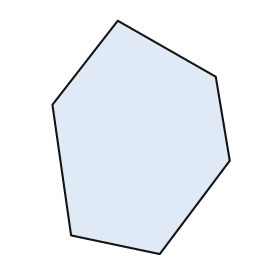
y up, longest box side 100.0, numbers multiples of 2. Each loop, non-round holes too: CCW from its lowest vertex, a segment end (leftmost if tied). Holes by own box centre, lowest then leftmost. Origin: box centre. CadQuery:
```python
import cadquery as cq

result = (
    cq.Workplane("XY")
    .moveTo(8.0, -50.0)
    .lineTo(38.0, -10.0)
    .lineTo(32.0, 26.0)
    .lineTo(-10.0, 50.0)
    .lineTo(-38.0, 14.0)
    .lineTo(-30.0, -42.0)
    .close()
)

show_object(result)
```